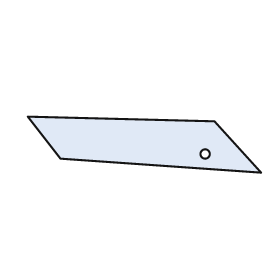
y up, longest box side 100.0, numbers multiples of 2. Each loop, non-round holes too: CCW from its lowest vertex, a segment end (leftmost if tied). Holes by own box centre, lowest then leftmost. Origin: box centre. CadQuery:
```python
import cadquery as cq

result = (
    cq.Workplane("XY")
    .moveTo(50.0, -12.0)
    .lineTo(30.0, 10.0)
    .lineTo(-50.0, 12.0)
    .lineTo(-36.0, -6.0)
    .close()
    .moveTo(26.0, -4.0)
    .circle(2.0)
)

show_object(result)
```